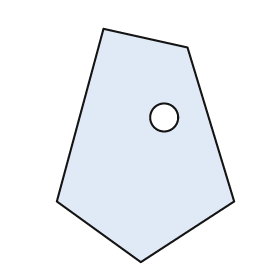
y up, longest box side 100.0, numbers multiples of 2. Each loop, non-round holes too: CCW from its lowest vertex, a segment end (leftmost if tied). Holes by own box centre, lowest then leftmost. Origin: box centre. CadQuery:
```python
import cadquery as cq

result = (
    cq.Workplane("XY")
    .moveTo(-2.0, -50.0)
    .lineTo(38.0, -24.0)
    .lineTo(18.0, 42.0)
    .lineTo(-18.0, 50.0)
    .lineTo(-38.0, -24.0)
    .close()
    .moveTo(8.0, 12.0)
    .circle(6.0)
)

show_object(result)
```